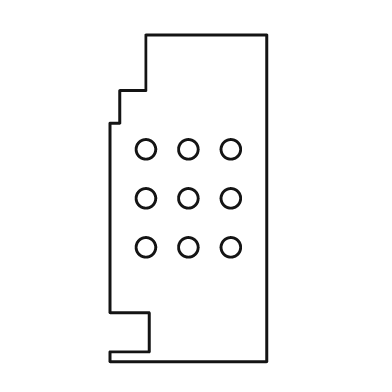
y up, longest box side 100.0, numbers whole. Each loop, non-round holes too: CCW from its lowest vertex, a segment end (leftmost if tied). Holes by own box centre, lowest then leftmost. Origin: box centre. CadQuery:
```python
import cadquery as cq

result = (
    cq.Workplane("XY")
    .moveTo(-24.0, -50.0)
    .lineTo(24.0, -50.0)
    .lineTo(24.0, 50.0)
    .lineTo(-13.0, 50.0)
    .lineTo(-13.0, 33.0)
    .lineTo(-21.0, 33.0)
    .lineTo(-21.0, 23.0)
    .lineTo(-24.0, 23.0)
    .lineTo(-24.0, -35.0)
    .lineTo(-12.0, -35.0)
    .lineTo(-12.0, -47.0)
    .lineTo(-24.0, -47.0)
    .close()
    .moveTo(-13.0, -15.0)
    .circle(3.0)
    .moveTo(0.0, -15.0)
    .circle(3.0)
    .moveTo(13.0, -15.0)
    .circle(3.0)
    .moveTo(-13.0, 0.0)
    .circle(3.0)
    .moveTo(0.0, 0.0)
    .circle(3.0)
    .moveTo(13.0, 0.0)
    .circle(3.0)
    .moveTo(-13.0, 15.0)
    .circle(3.0)
    .moveTo(0.0, 15.0)
    .circle(3.0)
    .moveTo(13.0, 15.0)
    .circle(3.0)
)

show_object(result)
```